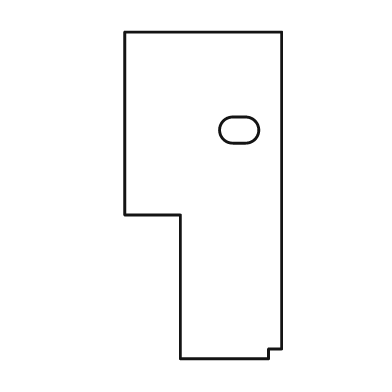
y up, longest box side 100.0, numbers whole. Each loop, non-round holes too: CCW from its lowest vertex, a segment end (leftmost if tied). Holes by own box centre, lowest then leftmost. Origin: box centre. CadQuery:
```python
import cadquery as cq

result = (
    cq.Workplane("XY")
    .moveTo(-7.0, -50.0)
    .lineTo(20.0, -50.0)
    .lineTo(20.0, -47.0)
    .lineTo(24.0, -47.0)
    .lineTo(24.0, 50.0)
    .lineTo(-24.0, 50.0)
    .lineTo(-24.0, -6.0)
    .lineTo(-7.0, -6.0)
    .close()
    .moveTo(9.0, 16.0)
    .lineTo(13.0, 16.0)
    .threePointArc((17.0, 20.0), (13.0, 24.0))
    .lineTo(9.0, 24.0)
    .threePointArc((5.0, 20.0), (9.0, 16.0))
    .close()
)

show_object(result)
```